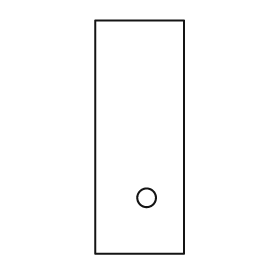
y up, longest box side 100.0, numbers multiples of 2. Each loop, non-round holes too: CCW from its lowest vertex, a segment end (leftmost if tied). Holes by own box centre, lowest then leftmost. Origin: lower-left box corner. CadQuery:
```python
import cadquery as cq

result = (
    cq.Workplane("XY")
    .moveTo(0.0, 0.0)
    .lineTo(38.0, 0.0)
    .lineTo(38.0, 100.0)
    .lineTo(0.0, 100.0)
    .close()
    .moveTo(22.0, 24.0)
    .circle(4.0)
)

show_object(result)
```